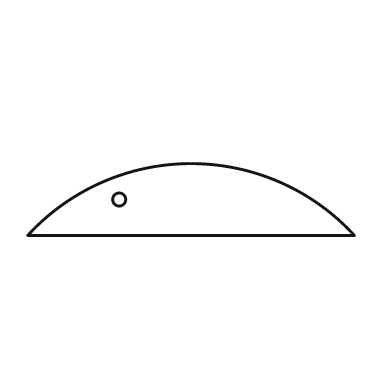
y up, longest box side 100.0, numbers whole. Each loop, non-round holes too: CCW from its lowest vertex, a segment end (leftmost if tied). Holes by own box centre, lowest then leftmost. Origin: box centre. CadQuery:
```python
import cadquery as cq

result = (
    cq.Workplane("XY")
    .moveTo(-50.0, -11.0)
    .lineTo(50.0, -11.0)
    .threePointArc((0.0, 11.0), (-50.0, -11.0))
    .close()
    .moveTo(-22.0, 0.0)
    .circle(2.0)
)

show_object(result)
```